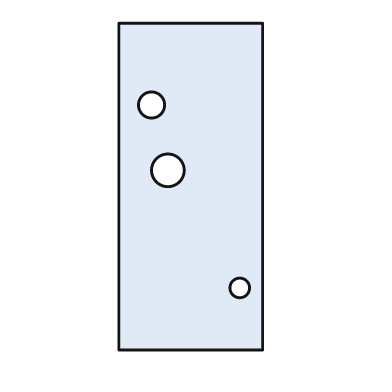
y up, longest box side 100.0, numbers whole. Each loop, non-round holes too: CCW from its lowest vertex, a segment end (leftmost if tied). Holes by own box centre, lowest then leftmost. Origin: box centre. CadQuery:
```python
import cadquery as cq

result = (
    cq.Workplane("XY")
    .moveTo(-22.0, -50.0)
    .lineTo(22.0, -50.0)
    .lineTo(22.0, 50.0)
    .lineTo(-22.0, 50.0)
    .close()
    .moveTo(15.0, -31.0)
    .circle(3.0)
    .moveTo(-7.0, 5.0)
    .circle(5.0)
    .moveTo(-12.0, 25.0)
    .circle(4.0)
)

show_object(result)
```